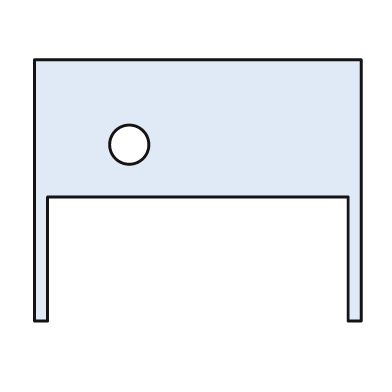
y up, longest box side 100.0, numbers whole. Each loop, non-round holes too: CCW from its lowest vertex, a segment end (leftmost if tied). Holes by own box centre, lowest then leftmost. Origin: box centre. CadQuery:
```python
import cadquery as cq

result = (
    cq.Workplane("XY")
    .moveTo(-50.0, -40.0)
    .lineTo(-46.0, -40.0)
    .lineTo(-46.0, -2.0)
    .lineTo(46.0, -2.0)
    .lineTo(46.0, -40.0)
    .lineTo(50.0, -40.0)
    .lineTo(50.0, 40.0)
    .lineTo(-50.0, 40.0)
    .close()
    .moveTo(-21.0, 14.0)
    .circle(6.0)
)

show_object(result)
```